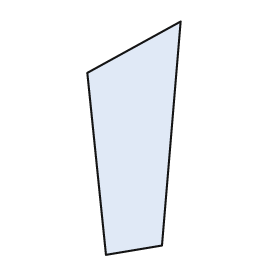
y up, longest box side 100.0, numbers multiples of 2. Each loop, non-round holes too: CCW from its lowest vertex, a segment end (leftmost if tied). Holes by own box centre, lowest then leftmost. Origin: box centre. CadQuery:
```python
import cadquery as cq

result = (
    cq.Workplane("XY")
    .moveTo(-12.0, -50.0)
    .lineTo(12.0, -46.0)
    .lineTo(20.0, 50.0)
    .lineTo(-20.0, 28.0)
    .close()
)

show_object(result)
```